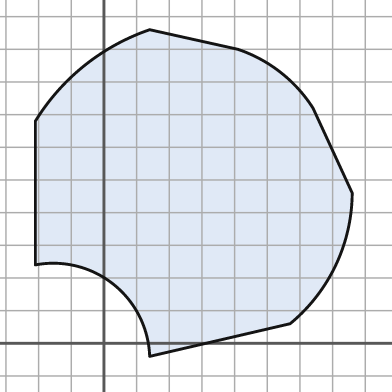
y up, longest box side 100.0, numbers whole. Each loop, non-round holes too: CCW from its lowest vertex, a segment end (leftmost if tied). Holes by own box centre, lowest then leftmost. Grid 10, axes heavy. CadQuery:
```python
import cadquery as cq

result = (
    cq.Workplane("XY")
    .moveTo(14.0, -4.0)
    .lineTo(57.0, 6.0)
    .threePointArc((71.0, 24.0), (76.0, 46.0))
    .lineTo(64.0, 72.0)
    .threePointArc((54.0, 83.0), (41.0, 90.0))
    .lineTo(14.0, 96.0)
    .threePointArc((-6.0, 85.0), (-21.0, 68.0))
    .lineTo(-21.0, 24.0)
    .threePointArc((3.0, 18.0), (14.0, -4.0))
    .close()
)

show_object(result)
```